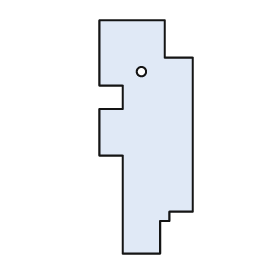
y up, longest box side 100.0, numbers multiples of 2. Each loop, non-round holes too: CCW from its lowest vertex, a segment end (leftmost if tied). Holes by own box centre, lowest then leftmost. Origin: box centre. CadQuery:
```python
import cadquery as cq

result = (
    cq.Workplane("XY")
    .moveTo(-10.0, -50.0)
    .lineTo(6.0, -50.0)
    .lineTo(6.0, -36.0)
    .lineTo(10.0, -36.0)
    .lineTo(10.0, -32.0)
    .lineTo(20.0, -32.0)
    .lineTo(20.0, 34.0)
    .lineTo(8.0, 34.0)
    .lineTo(8.0, 50.0)
    .lineTo(-20.0, 50.0)
    .lineTo(-20.0, 22.0)
    .lineTo(-10.0, 22.0)
    .lineTo(-10.0, 12.0)
    .lineTo(-20.0, 12.0)
    .lineTo(-20.0, -8.0)
    .lineTo(-10.0, -8.0)
    .close()
    .moveTo(-2.0, 28.0)
    .circle(2.0)
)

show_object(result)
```